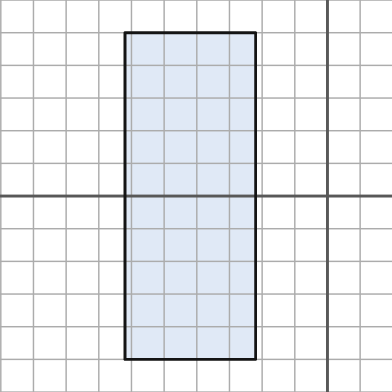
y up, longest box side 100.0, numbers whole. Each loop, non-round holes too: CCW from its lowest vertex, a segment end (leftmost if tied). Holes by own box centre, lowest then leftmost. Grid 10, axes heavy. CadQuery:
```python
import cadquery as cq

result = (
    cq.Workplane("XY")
    .moveTo(-62.0, -50.0)
    .lineTo(-22.0, -50.0)
    .lineTo(-22.0, 50.0)
    .lineTo(-62.0, 50.0)
    .close()
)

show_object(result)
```